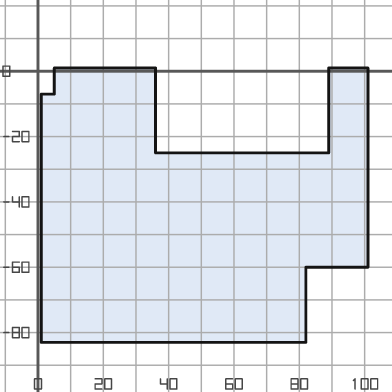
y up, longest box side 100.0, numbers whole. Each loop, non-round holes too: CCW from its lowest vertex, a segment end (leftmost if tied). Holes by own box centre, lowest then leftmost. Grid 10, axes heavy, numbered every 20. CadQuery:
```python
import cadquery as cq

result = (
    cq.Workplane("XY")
    .moveTo(1.0, -83.0)
    .lineTo(82.0, -83.0)
    .lineTo(82.0, -60.0)
    .lineTo(101.0, -60.0)
    .lineTo(101.0, 1.0)
    .lineTo(89.0, 1.0)
    .lineTo(89.0, -25.0)
    .lineTo(36.0, -25.0)
    .lineTo(36.0, 1.0)
    .lineTo(5.0, 1.0)
    .lineTo(5.0, -7.0)
    .lineTo(1.0, -7.0)
    .close()
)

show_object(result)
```